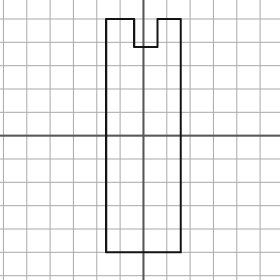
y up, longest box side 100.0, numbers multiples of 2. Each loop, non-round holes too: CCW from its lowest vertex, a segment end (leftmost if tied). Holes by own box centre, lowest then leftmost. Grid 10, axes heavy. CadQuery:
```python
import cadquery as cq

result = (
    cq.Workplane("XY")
    .moveTo(-16.0, -50.0)
    .lineTo(16.0, -50.0)
    .lineTo(16.0, 50.0)
    .lineTo(6.0, 50.0)
    .lineTo(6.0, 38.0)
    .lineTo(-4.0, 38.0)
    .lineTo(-4.0, 50.0)
    .lineTo(-16.0, 50.0)
    .close()
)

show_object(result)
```